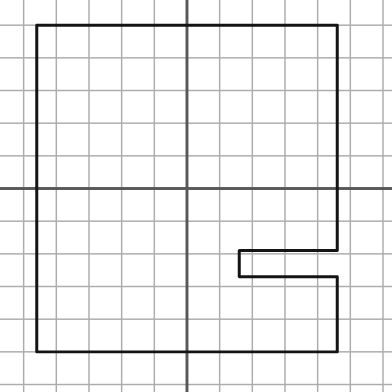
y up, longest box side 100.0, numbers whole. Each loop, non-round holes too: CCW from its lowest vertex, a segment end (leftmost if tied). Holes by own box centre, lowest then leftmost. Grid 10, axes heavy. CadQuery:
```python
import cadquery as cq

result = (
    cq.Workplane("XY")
    .moveTo(-46.0, -50.0)
    .lineTo(46.0, -50.0)
    .lineTo(46.0, -27.0)
    .lineTo(16.0, -27.0)
    .lineTo(16.0, -19.0)
    .lineTo(46.0, -19.0)
    .lineTo(46.0, 50.0)
    .lineTo(-46.0, 50.0)
    .close()
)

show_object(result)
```